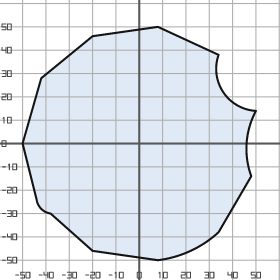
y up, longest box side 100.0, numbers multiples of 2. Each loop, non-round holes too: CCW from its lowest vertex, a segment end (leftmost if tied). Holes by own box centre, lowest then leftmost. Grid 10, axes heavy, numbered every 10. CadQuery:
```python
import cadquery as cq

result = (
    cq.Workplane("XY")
    .moveTo(8.0, -50.0)
    .threePointArc((22.0, -46.0), (34.0, -38.0))
    .lineTo(48.0, -14.0)
    .threePointArc((46.0, 0.0), (50.0, 14.0))
    .threePointArc((36.0, 22.0), (34.0, 38.0))
    .lineTo(8.0, 50.0)
    .lineTo(-20.0, 46.0)
    .lineTo(-42.0, 28.0)
    .lineTo(-50.0, 0.0)
    .lineTo(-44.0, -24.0)
    .threePointArc((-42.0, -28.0), (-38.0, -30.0))
    .lineTo(-20.0, -46.0)
    .close()
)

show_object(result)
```